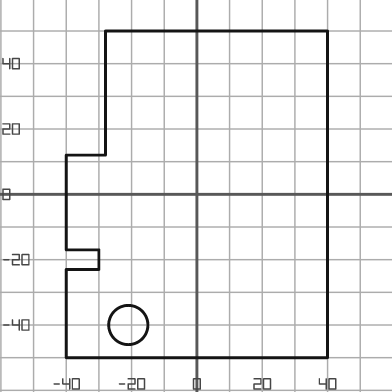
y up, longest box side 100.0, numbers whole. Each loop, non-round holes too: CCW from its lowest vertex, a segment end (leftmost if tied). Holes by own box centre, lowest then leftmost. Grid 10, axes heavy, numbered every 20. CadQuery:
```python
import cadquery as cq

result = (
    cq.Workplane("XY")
    .moveTo(-40.0, -50.0)
    .lineTo(40.0, -50.0)
    .lineTo(40.0, 50.0)
    .lineTo(-28.0, 50.0)
    .lineTo(-28.0, 12.0)
    .lineTo(-40.0, 12.0)
    .lineTo(-40.0, -17.0)
    .lineTo(-30.0, -17.0)
    .lineTo(-30.0, -23.0)
    .lineTo(-40.0, -23.0)
    .close()
    .moveTo(-21.0, -40.0)
    .circle(6.0)
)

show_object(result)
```